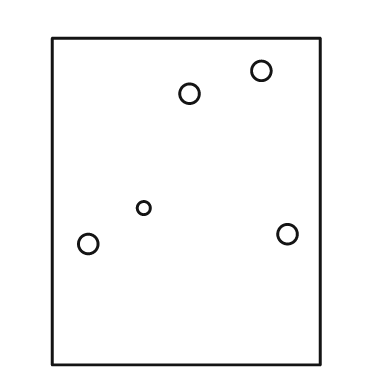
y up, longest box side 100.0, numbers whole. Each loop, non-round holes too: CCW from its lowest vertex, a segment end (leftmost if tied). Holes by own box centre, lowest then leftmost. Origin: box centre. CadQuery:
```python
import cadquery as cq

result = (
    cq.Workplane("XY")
    .moveTo(-41.0, -50.0)
    .lineTo(41.0, -50.0)
    .lineTo(41.0, 50.0)
    .lineTo(-41.0, 50.0)
    .close()
    .moveTo(-30.0, -13.0)
    .circle(3.0)
    .moveTo(31.0, -10.0)
    .circle(3.0)
    .moveTo(-13.0, -2.0)
    .circle(2.0)
    .moveTo(1.0, 33.0)
    .circle(3.0)
    .moveTo(23.0, 40.0)
    .circle(3.0)
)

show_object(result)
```